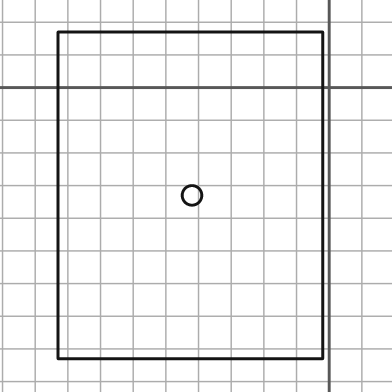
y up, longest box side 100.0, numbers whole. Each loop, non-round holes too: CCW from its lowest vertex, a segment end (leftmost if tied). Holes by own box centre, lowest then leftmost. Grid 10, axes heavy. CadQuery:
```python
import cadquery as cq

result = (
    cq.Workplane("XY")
    .moveTo(-83.0, -83.0)
    .lineTo(-2.0, -83.0)
    .lineTo(-2.0, 17.0)
    .lineTo(-83.0, 17.0)
    .close()
    .moveTo(-42.0, -33.0)
    .circle(3.0)
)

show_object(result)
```